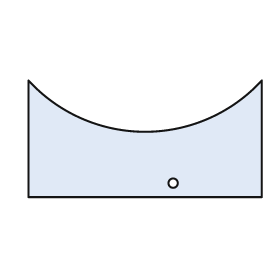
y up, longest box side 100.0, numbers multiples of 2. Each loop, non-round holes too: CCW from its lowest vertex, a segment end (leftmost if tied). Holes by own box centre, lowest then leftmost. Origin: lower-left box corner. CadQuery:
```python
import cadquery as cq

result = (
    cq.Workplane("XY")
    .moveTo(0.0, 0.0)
    .lineTo(100.0, 0.0)
    .lineTo(100.0, 50.0)
    .threePointArc((50.0, 28.0), (0.0, 50.0))
    .close()
    .moveTo(62.0, 6.0)
    .circle(2.0)
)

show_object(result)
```